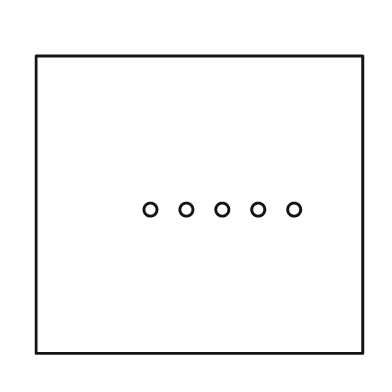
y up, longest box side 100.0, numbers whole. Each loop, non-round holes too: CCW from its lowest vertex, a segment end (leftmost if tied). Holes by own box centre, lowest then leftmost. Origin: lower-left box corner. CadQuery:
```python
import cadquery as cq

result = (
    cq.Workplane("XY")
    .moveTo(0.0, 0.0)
    .lineTo(100.0, 0.0)
    .lineTo(100.0, 91.0)
    .lineTo(0.0, 91.0)
    .close()
    .moveTo(35.0, 44.0)
    .circle(2.0)
    .moveTo(46.0, 44.0)
    .circle(2.0)
    .moveTo(57.0, 44.0)
    .circle(2.0)
    .moveTo(68.0, 44.0)
    .circle(2.0)
    .moveTo(79.0, 44.0)
    .circle(2.0)
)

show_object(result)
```